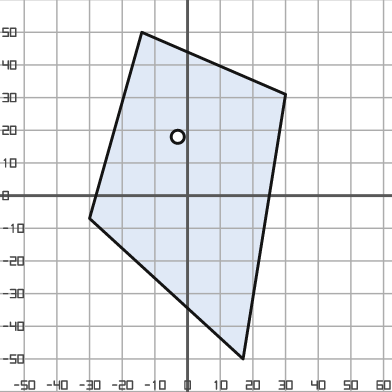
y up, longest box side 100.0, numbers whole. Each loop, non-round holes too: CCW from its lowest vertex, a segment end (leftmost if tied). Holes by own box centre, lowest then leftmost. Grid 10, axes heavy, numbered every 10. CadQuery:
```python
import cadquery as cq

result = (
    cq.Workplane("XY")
    .moveTo(17.0, -50.0)
    .lineTo(30.0, 31.0)
    .lineTo(-14.0, 50.0)
    .lineTo(-30.0, -7.0)
    .close()
    .moveTo(-3.0, 18.0)
    .circle(2.0)
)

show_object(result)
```